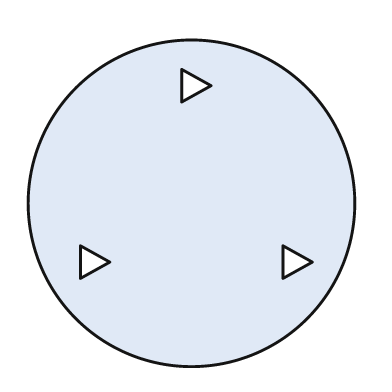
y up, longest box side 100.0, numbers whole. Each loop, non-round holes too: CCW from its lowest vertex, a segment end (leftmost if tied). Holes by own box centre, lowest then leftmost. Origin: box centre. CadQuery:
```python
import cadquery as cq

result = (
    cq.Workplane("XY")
    .moveTo(0.0, 0.0)
    .circle(50.0)
    .moveTo(-34.0, -23.0)
    .lineTo(-25.0, -18.0)
    .lineTo(-34.0, -13.0)
    .close()
    .moveTo(28.0, -23.0)
    .lineTo(37.0, -18.0)
    .lineTo(28.0, -13.0)
    .close()
    .moveTo(-3.0, 31.0)
    .lineTo(6.0, 36.0)
    .lineTo(-3.0, 41.0)
    .close()
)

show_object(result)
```